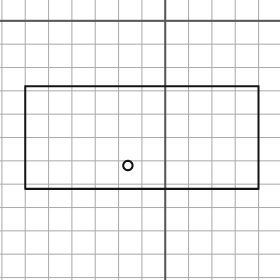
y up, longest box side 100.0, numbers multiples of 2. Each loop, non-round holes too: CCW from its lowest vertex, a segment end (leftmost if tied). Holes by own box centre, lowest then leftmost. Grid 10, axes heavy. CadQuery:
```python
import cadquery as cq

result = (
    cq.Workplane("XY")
    .moveTo(-60.0, -72.0)
    .lineTo(40.0, -72.0)
    .lineTo(40.0, -28.0)
    .lineTo(-60.0, -28.0)
    .close()
    .moveTo(-16.0, -62.0)
    .circle(2.0)
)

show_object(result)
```